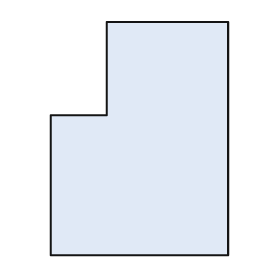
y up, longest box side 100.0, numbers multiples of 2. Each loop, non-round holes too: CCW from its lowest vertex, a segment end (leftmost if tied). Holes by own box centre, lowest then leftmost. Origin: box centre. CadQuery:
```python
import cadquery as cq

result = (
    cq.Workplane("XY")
    .moveTo(-38.0, -50.0)
    .lineTo(38.0, -50.0)
    .lineTo(38.0, 50.0)
    .lineTo(-14.0, 50.0)
    .lineTo(-14.0, 10.0)
    .lineTo(-38.0, 10.0)
    .close()
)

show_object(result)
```